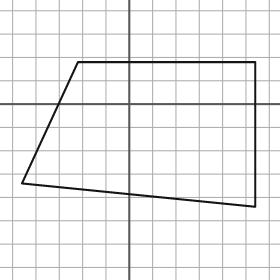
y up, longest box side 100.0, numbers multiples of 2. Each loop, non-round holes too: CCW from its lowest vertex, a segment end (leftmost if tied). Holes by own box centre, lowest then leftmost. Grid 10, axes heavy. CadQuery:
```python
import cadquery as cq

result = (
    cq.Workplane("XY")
    .moveTo(54.0, -44.0)
    .lineTo(54.0, 18.0)
    .lineTo(-22.0, 18.0)
    .lineTo(-46.0, -34.0)
    .close()
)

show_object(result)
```